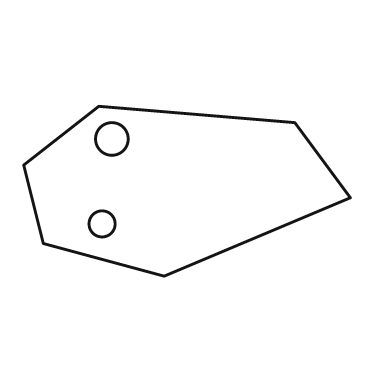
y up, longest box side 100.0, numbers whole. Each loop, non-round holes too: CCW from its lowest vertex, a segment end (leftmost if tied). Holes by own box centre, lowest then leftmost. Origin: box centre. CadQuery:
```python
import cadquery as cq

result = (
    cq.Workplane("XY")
    .moveTo(-7.0, -26.0)
    .lineTo(50.0, -2.0)
    .lineTo(33.0, 21.0)
    .lineTo(-27.0, 26.0)
    .lineTo(-50.0, 8.0)
    .lineTo(-44.0, -16.0)
    .close()
    .moveTo(-26.0, -10.0)
    .circle(4.0)
    .moveTo(-23.0, 16.0)
    .circle(5.0)
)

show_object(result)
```